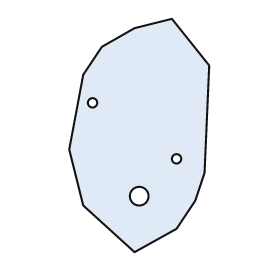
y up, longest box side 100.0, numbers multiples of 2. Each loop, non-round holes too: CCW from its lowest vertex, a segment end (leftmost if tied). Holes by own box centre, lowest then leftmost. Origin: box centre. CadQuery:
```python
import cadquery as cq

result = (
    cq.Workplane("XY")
    .moveTo(-2.0, -50.0)
    .lineTo(16.0, -40.0)
    .lineTo(24.0, -28.0)
    .lineTo(28.0, -16.0)
    .lineTo(30.0, 30.0)
    .lineTo(14.0, 50.0)
    .lineTo(-2.0, 46.0)
    .lineTo(-16.0, 38.0)
    .lineTo(-24.0, 26.0)
    .lineTo(-30.0, -6.0)
    .lineTo(-24.0, -30.0)
    .close()
    .moveTo(0.0, -26.0)
    .circle(4.0)
    .moveTo(16.0, -10.0)
    .circle(2.0)
    .moveTo(-20.0, 14.0)
    .circle(2.0)
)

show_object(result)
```